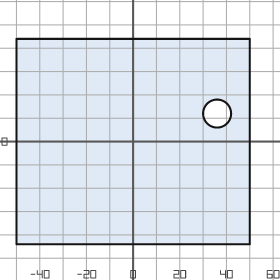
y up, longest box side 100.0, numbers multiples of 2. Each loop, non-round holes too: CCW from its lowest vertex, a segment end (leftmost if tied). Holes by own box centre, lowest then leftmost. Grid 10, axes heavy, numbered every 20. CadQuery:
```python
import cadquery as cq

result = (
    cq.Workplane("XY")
    .moveTo(-50.0, -44.0)
    .lineTo(50.0, -44.0)
    .lineTo(50.0, 44.0)
    .lineTo(-50.0, 44.0)
    .close()
    .moveTo(36.0, 12.0)
    .circle(6.0)
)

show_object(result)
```